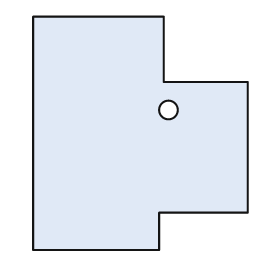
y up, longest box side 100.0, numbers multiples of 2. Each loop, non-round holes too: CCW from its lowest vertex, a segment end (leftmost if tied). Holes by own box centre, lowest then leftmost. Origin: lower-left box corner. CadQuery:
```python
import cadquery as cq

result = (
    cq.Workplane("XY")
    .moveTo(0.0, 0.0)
    .lineTo(54.0, 0.0)
    .lineTo(54.0, 16.0)
    .lineTo(92.0, 16.0)
    .lineTo(92.0, 72.0)
    .lineTo(56.0, 72.0)
    .lineTo(56.0, 100.0)
    .lineTo(0.0, 100.0)
    .close()
    .moveTo(58.0, 60.0)
    .circle(4.0)
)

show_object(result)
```